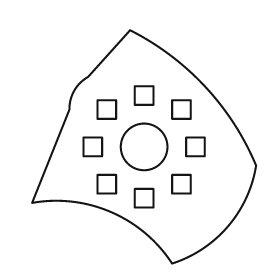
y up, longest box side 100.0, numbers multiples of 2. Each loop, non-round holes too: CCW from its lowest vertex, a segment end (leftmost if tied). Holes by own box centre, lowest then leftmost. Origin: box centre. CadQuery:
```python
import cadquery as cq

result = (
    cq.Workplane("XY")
    .moveTo(12.0, -50.0)
    .threePointArc((36.0, -34.0), (48.0, -8.0))
    .threePointArc((26.0, 26.0), (-6.0, 50.0))
    .lineTo(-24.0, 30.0)
    .threePointArc((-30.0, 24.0), (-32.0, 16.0))
    .lineTo(-48.0, -24.0)
    .threePointArc((-14.0, -28.0), (12.0, -50.0))
    .close()
    .moveTo(-4.0, -26.0)
    .lineTo(4.0, -26.0)
    .lineTo(4.0, -18.0)
    .lineTo(-4.0, -18.0)
    .close()
    .moveTo(-20.0, -20.0)
    .lineTo(-12.0, -20.0)
    .lineTo(-12.0, -12.0)
    .lineTo(-20.0, -12.0)
    .close()
    .moveTo(12.0, -20.0)
    .lineTo(20.0, -20.0)
    .lineTo(20.0, -12.0)
    .lineTo(12.0, -12.0)
    .close()
    .moveTo(-26.0, -4.0)
    .lineTo(-18.0, -4.0)
    .lineTo(-18.0, 4.0)
    .lineTo(-26.0, 4.0)
    .close()
    .moveTo(0.0, 0.0)
    .circle(10.0)
    .moveTo(18.0, -4.0)
    .lineTo(26.0, -4.0)
    .lineTo(26.0, 4.0)
    .lineTo(18.0, 4.0)
    .close()
    .moveTo(-20.0, 12.0)
    .lineTo(-12.0, 12.0)
    .lineTo(-12.0, 20.0)
    .lineTo(-20.0, 20.0)
    .close()
    .moveTo(12.0, 12.0)
    .lineTo(20.0, 12.0)
    .lineTo(20.0, 20.0)
    .lineTo(12.0, 20.0)
    .close()
    .moveTo(-4.0, 18.0)
    .lineTo(4.0, 18.0)
    .lineTo(4.0, 26.0)
    .lineTo(-4.0, 26.0)
    .close()
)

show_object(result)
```